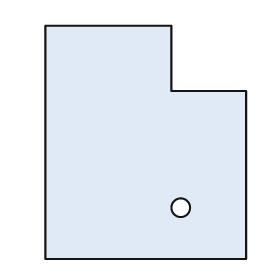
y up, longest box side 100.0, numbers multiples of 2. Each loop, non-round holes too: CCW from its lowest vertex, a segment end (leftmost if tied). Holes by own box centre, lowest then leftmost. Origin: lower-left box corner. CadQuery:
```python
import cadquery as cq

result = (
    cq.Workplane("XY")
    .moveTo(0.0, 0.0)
    .lineTo(86.0, 0.0)
    .lineTo(86.0, 72.0)
    .lineTo(54.0, 72.0)
    .lineTo(54.0, 100.0)
    .lineTo(0.0, 100.0)
    .close()
    .moveTo(58.0, 22.0)
    .circle(4.0)
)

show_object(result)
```